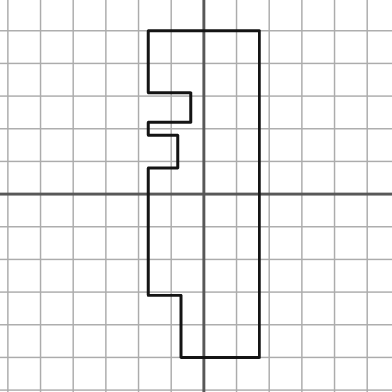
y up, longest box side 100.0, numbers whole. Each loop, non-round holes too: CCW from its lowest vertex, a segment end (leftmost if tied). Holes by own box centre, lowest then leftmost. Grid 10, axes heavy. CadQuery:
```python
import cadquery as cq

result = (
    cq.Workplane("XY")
    .moveTo(-7.0, -50.0)
    .lineTo(17.0, -50.0)
    .lineTo(17.0, 50.0)
    .lineTo(-17.0, 50.0)
    .lineTo(-17.0, 31.0)
    .lineTo(-4.0, 31.0)
    .lineTo(-4.0, 22.0)
    .lineTo(-17.0, 22.0)
    .lineTo(-17.0, 18.0)
    .lineTo(-8.0, 18.0)
    .lineTo(-8.0, 8.0)
    .lineTo(-17.0, 8.0)
    .lineTo(-17.0, -31.0)
    .lineTo(-7.0, -31.0)
    .close()
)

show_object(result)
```